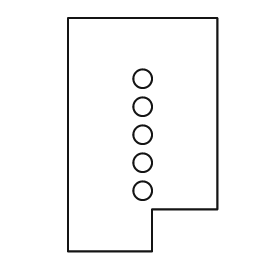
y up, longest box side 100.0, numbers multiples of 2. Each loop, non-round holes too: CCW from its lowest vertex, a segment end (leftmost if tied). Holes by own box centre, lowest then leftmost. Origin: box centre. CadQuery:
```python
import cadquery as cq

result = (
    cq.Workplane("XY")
    .moveTo(-32.0, -50.0)
    .lineTo(4.0, -50.0)
    .lineTo(4.0, -32.0)
    .lineTo(32.0, -32.0)
    .lineTo(32.0, 50.0)
    .lineTo(-32.0, 50.0)
    .close()
    .moveTo(0.0, -24.0)
    .circle(4.0)
    .moveTo(0.0, -12.0)
    .circle(4.0)
    .moveTo(0.0, 0.0)
    .circle(4.0)
    .moveTo(0.0, 12.0)
    .circle(4.0)
    .moveTo(0.0, 24.0)
    .circle(4.0)
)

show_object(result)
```